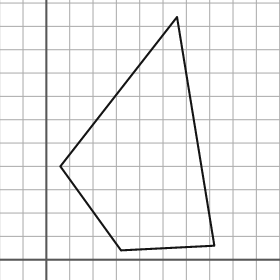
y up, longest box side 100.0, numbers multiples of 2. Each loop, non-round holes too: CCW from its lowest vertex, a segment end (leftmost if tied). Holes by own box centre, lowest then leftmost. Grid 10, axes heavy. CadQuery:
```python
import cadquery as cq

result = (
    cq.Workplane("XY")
    .moveTo(32.0, 4.0)
    .lineTo(72.0, 6.0)
    .lineTo(56.0, 104.0)
    .lineTo(6.0, 40.0)
    .close()
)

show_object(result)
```